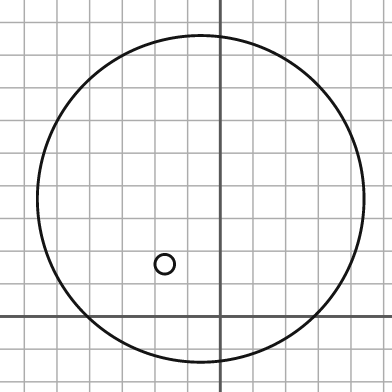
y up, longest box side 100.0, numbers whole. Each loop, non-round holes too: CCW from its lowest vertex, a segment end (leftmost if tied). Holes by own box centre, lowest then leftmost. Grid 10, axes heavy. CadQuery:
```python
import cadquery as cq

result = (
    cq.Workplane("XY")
    .moveTo(-6.0, 36.0)
    .circle(50.0)
    .moveTo(-17.0, 16.0)
    .circle(3.0)
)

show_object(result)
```